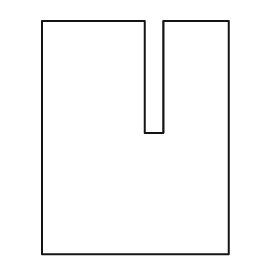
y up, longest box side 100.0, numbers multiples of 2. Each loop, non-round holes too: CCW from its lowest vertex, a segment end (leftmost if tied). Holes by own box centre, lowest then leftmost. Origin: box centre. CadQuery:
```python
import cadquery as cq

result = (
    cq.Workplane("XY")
    .moveTo(-40.0, -50.0)
    .lineTo(40.0, -50.0)
    .lineTo(40.0, 50.0)
    .lineTo(12.0, 50.0)
    .lineTo(12.0, 2.0)
    .lineTo(4.0, 2.0)
    .lineTo(4.0, 50.0)
    .lineTo(-40.0, 50.0)
    .close()
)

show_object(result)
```